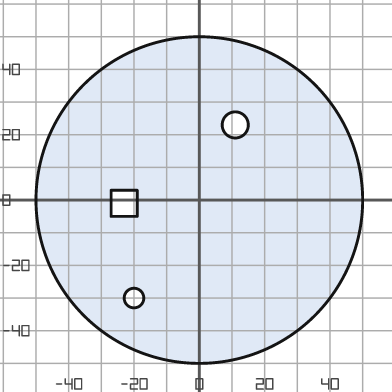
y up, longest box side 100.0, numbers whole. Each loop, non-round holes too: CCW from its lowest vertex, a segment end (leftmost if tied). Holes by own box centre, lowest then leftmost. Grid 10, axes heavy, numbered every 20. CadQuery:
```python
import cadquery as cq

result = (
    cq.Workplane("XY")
    .moveTo(0.0, 0.0)
    .circle(50.0)
    .moveTo(-20.0, -30.0)
    .circle(3.0)
    .moveTo(-27.0, -5.0)
    .lineTo(-19.0, -5.0)
    .lineTo(-19.0, 3.0)
    .lineTo(-27.0, 3.0)
    .close()
    .moveTo(11.0, 23.0)
    .circle(4.0)
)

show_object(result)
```